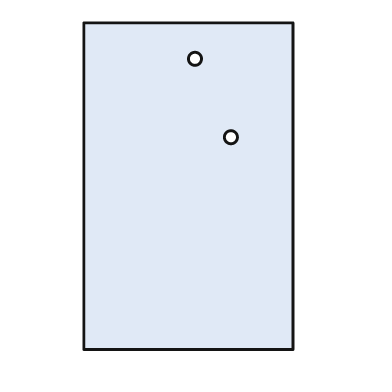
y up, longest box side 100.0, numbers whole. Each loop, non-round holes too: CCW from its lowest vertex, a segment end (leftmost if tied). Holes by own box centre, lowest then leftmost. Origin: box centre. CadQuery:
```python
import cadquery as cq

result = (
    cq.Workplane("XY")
    .moveTo(-32.0, -50.0)
    .lineTo(32.0, -50.0)
    .lineTo(32.0, 50.0)
    .lineTo(-32.0, 50.0)
    .close()
    .moveTo(13.0, 15.0)
    .circle(2.0)
    .moveTo(2.0, 39.0)
    .circle(2.0)
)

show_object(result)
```